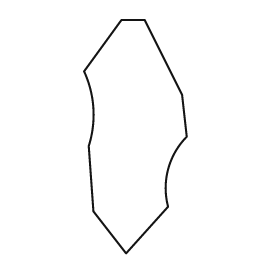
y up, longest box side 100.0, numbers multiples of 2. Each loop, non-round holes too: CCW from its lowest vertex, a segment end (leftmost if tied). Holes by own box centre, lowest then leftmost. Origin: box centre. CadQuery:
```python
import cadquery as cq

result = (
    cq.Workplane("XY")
    .moveTo(-4.0, -50.0)
    .lineTo(14.0, -30.0)
    .threePointArc((14.0, -14.0), (22.0, 0.0))
    .lineTo(20.0, 18.0)
    .lineTo(4.0, 50.0)
    .lineTo(-6.0, 50.0)
    .lineTo(-22.0, 28.0)
    .threePointArc((-18.0, 12.0), (-20.0, -4.0))
    .lineTo(-18.0, -32.0)
    .close()
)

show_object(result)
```